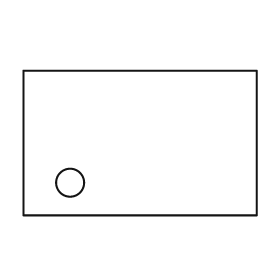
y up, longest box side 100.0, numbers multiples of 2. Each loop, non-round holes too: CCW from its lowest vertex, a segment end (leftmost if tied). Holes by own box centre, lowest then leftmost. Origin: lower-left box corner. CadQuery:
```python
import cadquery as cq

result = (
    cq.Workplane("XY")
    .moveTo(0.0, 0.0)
    .lineTo(100.0, 0.0)
    .lineTo(100.0, 62.0)
    .lineTo(0.0, 62.0)
    .close()
    .moveTo(20.0, 14.0)
    .circle(6.0)
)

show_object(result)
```